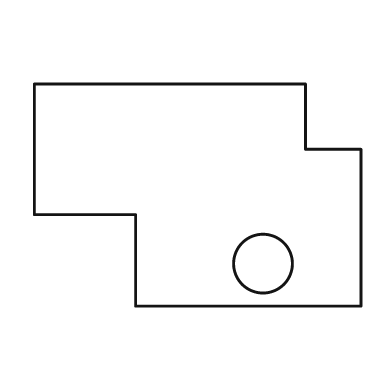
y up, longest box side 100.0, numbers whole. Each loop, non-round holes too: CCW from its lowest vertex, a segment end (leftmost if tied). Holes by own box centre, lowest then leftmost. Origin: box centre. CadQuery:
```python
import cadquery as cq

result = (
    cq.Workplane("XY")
    .moveTo(-19.0, -34.0)
    .lineTo(50.0, -34.0)
    .lineTo(50.0, 14.0)
    .lineTo(33.0, 14.0)
    .lineTo(33.0, 34.0)
    .lineTo(-50.0, 34.0)
    .lineTo(-50.0, -6.0)
    .lineTo(-19.0, -6.0)
    .close()
    .moveTo(20.0, -21.0)
    .circle(9.0)
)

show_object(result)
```